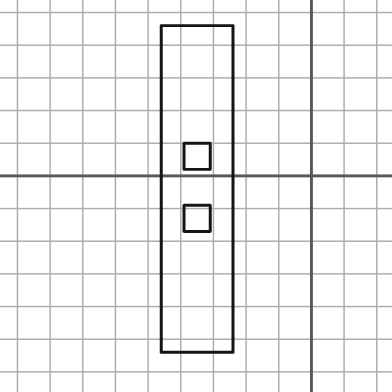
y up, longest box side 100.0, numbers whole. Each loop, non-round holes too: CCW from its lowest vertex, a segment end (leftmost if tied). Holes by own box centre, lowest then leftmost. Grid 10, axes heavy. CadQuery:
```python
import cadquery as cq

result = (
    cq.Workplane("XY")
    .moveTo(-46.0, -54.0)
    .lineTo(-24.0, -54.0)
    .lineTo(-24.0, 46.0)
    .lineTo(-46.0, 46.0)
    .close()
    .moveTo(-39.0, -17.0)
    .lineTo(-31.0, -17.0)
    .lineTo(-31.0, -9.0)
    .lineTo(-39.0, -9.0)
    .close()
    .moveTo(-39.0, 2.0)
    .lineTo(-31.0, 2.0)
    .lineTo(-31.0, 10.0)
    .lineTo(-39.0, 10.0)
    .close()
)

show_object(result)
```